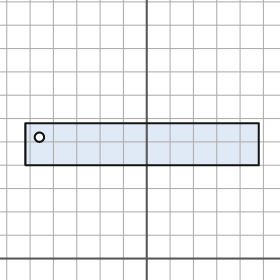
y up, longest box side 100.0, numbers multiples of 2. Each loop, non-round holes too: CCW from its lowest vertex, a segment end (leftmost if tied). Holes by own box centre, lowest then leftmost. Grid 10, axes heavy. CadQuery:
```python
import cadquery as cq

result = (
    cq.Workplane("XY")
    .moveTo(-52.0, 40.0)
    .lineTo(48.0, 40.0)
    .lineTo(48.0, 58.0)
    .lineTo(-52.0, 58.0)
    .close()
    .moveTo(-46.0, 52.0)
    .circle(2.0)
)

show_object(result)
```